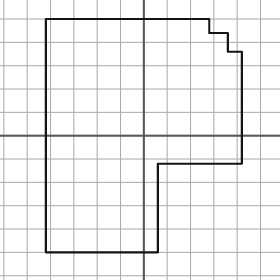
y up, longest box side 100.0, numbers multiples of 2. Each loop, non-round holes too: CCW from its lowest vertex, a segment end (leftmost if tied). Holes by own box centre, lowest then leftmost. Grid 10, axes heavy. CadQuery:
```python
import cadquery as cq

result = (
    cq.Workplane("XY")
    .moveTo(-42.0, -50.0)
    .lineTo(6.0, -50.0)
    .lineTo(6.0, -12.0)
    .lineTo(42.0, -12.0)
    .lineTo(42.0, 36.0)
    .lineTo(36.0, 36.0)
    .lineTo(36.0, 44.0)
    .lineTo(28.0, 44.0)
    .lineTo(28.0, 50.0)
    .lineTo(-42.0, 50.0)
    .close()
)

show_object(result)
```